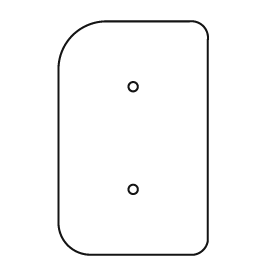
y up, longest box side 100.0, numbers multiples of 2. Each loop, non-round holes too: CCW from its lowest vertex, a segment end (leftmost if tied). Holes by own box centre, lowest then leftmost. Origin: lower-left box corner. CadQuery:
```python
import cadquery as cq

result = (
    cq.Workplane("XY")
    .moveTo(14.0, 0.0)
    .lineTo(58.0, 0.0)
    .threePointArc((62.0, 2.0), (64.0, 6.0))
    .lineTo(64.0, 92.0)
    .threePointArc((62.0, 98.0), (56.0, 100.0))
    .lineTo(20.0, 100.0)
    .threePointArc((6.0, 94.0), (0.0, 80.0))
    .lineTo(0.0, 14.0)
    .threePointArc((4.0, 4.0), (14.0, 0.0))
    .close()
    .moveTo(32.0, 28.0)
    .circle(2.0)
    .moveTo(32.0, 72.0)
    .circle(2.0)
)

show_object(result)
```